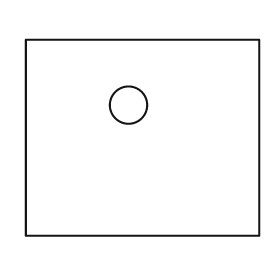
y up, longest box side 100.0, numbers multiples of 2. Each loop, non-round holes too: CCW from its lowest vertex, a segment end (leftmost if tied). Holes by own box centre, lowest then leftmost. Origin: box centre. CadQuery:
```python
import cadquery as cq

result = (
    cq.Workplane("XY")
    .moveTo(-50.0, -42.0)
    .lineTo(50.0, -42.0)
    .lineTo(50.0, 42.0)
    .lineTo(-50.0, 42.0)
    .close()
    .moveTo(-6.0, 14.0)
    .circle(8.0)
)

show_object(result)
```